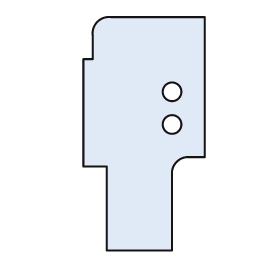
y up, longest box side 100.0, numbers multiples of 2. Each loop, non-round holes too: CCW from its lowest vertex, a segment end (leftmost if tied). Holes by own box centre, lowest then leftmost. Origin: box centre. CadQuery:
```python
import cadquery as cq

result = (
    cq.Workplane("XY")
    .moveTo(-16.0, -50.0)
    .lineTo(12.0, -50.0)
    .lineTo(12.0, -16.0)
    .threePointArc((14.0, -12.0), (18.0, -10.0))
    .lineTo(26.0, -10.0)
    .lineTo(26.0, 50.0)
    .lineTo(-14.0, 50.0)
    .threePointArc((-20.0, 48.0), (-22.0, 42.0))
    .lineTo(-22.0, 32.0)
    .lineTo(-26.0, 32.0)
    .lineTo(-26.0, -14.0)
    .lineTo(-16.0, -14.0)
    .close()
    .moveTo(12.0, 4.0)
    .circle(4.0)
    .moveTo(12.0, 18.0)
    .circle(4.0)
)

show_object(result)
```